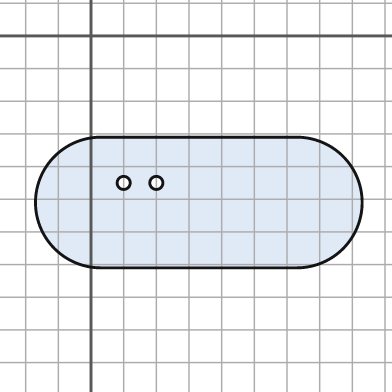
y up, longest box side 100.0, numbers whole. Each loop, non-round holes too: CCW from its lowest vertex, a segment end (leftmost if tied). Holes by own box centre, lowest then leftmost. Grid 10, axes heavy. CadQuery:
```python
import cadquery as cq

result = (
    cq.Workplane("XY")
    .moveTo(3.0, -71.0)
    .lineTo(63.0, -71.0)
    .threePointArc((83.0, -51.0), (63.0, -31.0))
    .lineTo(3.0, -31.0)
    .threePointArc((-17.0, -51.0), (3.0, -71.0))
    .close()
    .moveTo(10.0, -45.0)
    .circle(2.0)
    .moveTo(20.0, -45.0)
    .circle(2.0)
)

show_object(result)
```